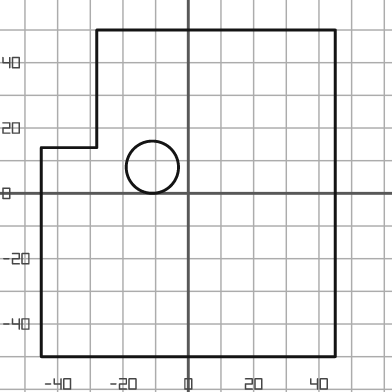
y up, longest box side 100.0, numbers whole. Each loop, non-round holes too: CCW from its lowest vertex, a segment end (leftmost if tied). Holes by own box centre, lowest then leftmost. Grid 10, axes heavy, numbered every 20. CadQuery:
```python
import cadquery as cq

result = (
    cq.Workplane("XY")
    .moveTo(-45.0, -50.0)
    .lineTo(45.0, -50.0)
    .lineTo(45.0, 50.0)
    .lineTo(-28.0, 50.0)
    .lineTo(-28.0, 14.0)
    .lineTo(-45.0, 14.0)
    .close()
    .moveTo(-11.0, 8.0)
    .circle(8.0)
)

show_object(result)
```